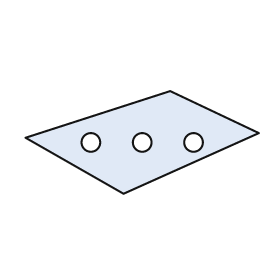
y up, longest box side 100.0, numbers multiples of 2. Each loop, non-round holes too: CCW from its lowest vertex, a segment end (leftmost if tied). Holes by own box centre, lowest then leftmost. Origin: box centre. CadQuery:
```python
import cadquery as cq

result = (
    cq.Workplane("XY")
    .moveTo(-8.0, -22.0)
    .lineTo(50.0, 4.0)
    .lineTo(12.0, 22.0)
    .lineTo(-50.0, 2.0)
    .close()
    .moveTo(-22.0, 0.0)
    .circle(4.0)
    .moveTo(0.0, 0.0)
    .circle(4.0)
    .moveTo(22.0, 0.0)
    .circle(4.0)
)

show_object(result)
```